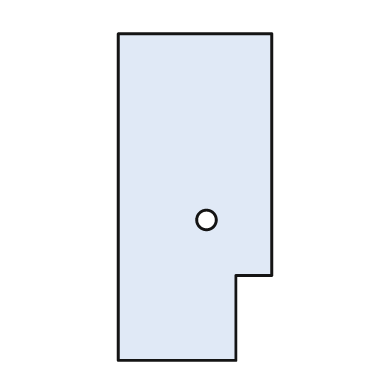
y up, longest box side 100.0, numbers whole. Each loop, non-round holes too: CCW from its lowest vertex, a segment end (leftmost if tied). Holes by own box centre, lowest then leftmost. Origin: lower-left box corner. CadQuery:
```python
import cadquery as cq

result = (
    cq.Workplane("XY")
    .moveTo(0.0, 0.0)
    .lineTo(36.0, 0.0)
    .lineTo(36.0, 26.0)
    .lineTo(47.0, 26.0)
    .lineTo(47.0, 100.0)
    .lineTo(0.0, 100.0)
    .close()
    .moveTo(27.0, 43.0)
    .circle(3.0)
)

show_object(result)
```